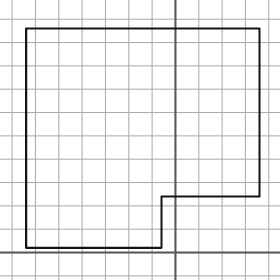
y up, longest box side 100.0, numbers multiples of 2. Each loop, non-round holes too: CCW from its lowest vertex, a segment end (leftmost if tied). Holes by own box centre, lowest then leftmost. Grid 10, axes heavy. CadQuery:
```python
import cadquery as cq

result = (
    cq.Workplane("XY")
    .moveTo(-64.0, 2.0)
    .lineTo(-6.0, 2.0)
    .lineTo(-6.0, 24.0)
    .lineTo(36.0, 24.0)
    .lineTo(36.0, 96.0)
    .lineTo(-64.0, 96.0)
    .close()
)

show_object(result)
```